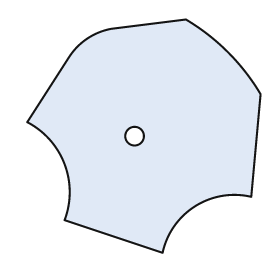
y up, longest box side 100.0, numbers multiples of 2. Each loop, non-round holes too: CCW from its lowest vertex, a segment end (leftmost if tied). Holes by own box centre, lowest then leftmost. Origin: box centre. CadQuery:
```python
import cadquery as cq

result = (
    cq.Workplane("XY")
    .moveTo(8.0, -50.0)
    .threePointArc((22.0, -30.0), (46.0, -26.0))
    .lineTo(50.0, 18.0)
    .threePointArc((36.0, 36.0), (18.0, 50.0))
    .lineTo(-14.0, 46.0)
    .threePointArc((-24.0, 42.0), (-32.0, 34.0))
    .lineTo(-50.0, 6.0)
    .threePointArc((-34.0, -12.0), (-34.0, -36.0))
    .close()
    .moveTo(-4.0, 0.0)
    .circle(4.0)
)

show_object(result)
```